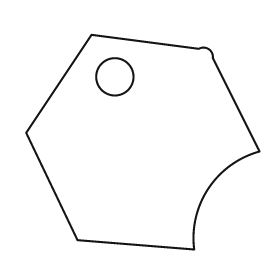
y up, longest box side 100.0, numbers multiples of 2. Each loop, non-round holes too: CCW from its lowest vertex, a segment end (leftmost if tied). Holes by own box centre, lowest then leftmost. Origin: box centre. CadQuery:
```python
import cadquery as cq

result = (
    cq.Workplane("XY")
    .moveTo(22.0, -46.0)
    .threePointArc((28.0, -20.0), (50.0, -4.0))
    .lineTo(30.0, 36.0)
    .threePointArc((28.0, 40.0), (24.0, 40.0))
    .lineTo(-22.0, 46.0)
    .lineTo(-50.0, 4.0)
    .lineTo(-28.0, -42.0)
    .close()
    .moveTo(-12.0, 28.0)
    .circle(8.0)
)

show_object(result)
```